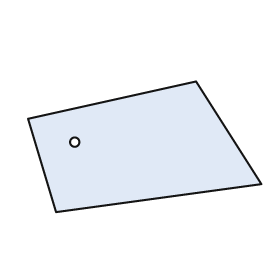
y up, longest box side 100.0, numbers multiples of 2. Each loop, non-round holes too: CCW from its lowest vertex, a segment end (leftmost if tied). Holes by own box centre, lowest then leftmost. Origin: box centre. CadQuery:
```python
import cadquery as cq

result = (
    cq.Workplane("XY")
    .moveTo(-38.0, -28.0)
    .lineTo(50.0, -16.0)
    .lineTo(22.0, 28.0)
    .lineTo(-50.0, 12.0)
    .close()
    .moveTo(-30.0, 2.0)
    .circle(2.0)
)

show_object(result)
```